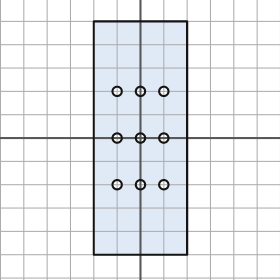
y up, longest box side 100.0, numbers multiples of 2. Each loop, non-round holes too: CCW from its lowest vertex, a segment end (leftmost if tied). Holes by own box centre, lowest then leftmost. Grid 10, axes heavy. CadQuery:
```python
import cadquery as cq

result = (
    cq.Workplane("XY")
    .moveTo(-20.0, -50.0)
    .lineTo(20.0, -50.0)
    .lineTo(20.0, 50.0)
    .lineTo(-20.0, 50.0)
    .close()
    .moveTo(-10.0, -20.0)
    .circle(2.0)
    .moveTo(0.0, -20.0)
    .circle(2.0)
    .moveTo(10.0, -20.0)
    .circle(2.0)
    .moveTo(-10.0, 0.0)
    .circle(2.0)
    .moveTo(0.0, 0.0)
    .circle(2.0)
    .moveTo(10.0, 0.0)
    .circle(2.0)
    .moveTo(-10.0, 20.0)
    .circle(2.0)
    .moveTo(0.0, 20.0)
    .circle(2.0)
    .moveTo(10.0, 20.0)
    .circle(2.0)
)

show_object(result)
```